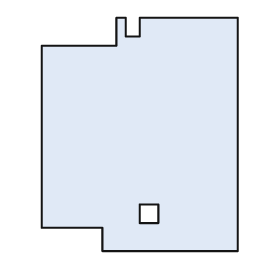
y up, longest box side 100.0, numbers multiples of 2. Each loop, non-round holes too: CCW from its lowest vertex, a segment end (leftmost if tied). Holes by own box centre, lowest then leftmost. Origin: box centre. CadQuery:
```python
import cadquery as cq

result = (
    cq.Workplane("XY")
    .moveTo(-16.0, -50.0)
    .lineTo(42.0, -50.0)
    .lineTo(42.0, 50.0)
    .lineTo(0.0, 50.0)
    .lineTo(0.0, 42.0)
    .lineTo(-6.0, 42.0)
    .lineTo(-6.0, 50.0)
    .lineTo(-10.0, 50.0)
    .lineTo(-10.0, 38.0)
    .lineTo(-42.0, 38.0)
    .lineTo(-42.0, -40.0)
    .lineTo(-16.0, -40.0)
    .close()
    .moveTo(0.0, -38.0)
    .lineTo(8.0, -38.0)
    .lineTo(8.0, -30.0)
    .lineTo(0.0, -30.0)
    .close()
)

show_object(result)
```